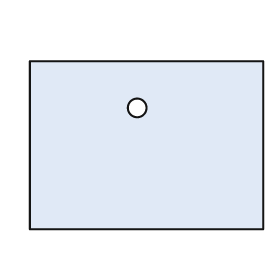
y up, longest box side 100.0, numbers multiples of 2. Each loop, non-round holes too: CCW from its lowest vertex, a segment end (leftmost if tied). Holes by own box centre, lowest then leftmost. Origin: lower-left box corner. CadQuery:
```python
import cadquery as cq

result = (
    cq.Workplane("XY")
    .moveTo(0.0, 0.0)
    .lineTo(100.0, 0.0)
    .lineTo(100.0, 72.0)
    .lineTo(0.0, 72.0)
    .close()
    .moveTo(46.0, 52.0)
    .circle(4.0)
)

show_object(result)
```